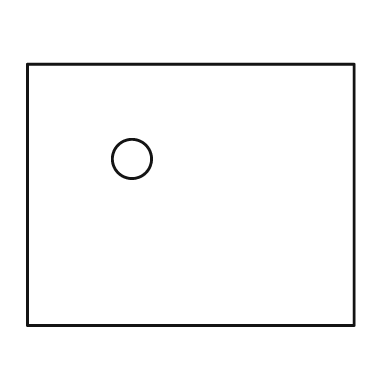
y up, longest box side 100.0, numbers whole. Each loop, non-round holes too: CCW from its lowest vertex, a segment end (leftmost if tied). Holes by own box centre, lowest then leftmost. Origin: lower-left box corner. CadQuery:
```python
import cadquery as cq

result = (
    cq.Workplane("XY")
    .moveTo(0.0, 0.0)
    .lineTo(100.0, 0.0)
    .lineTo(100.0, 80.0)
    .lineTo(0.0, 80.0)
    .close()
    .moveTo(32.0, 51.0)
    .circle(6.0)
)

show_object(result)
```